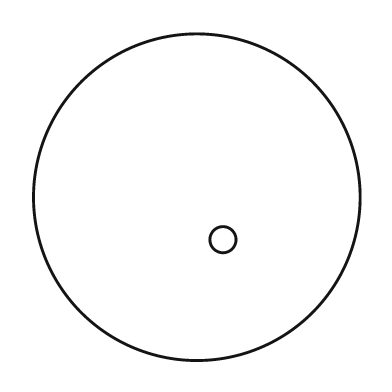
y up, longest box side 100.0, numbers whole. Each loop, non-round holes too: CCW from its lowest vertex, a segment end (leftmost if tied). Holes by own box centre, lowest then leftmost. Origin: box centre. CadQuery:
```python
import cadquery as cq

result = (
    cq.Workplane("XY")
    .moveTo(0.0, 0.0)
    .circle(50.0)
    .moveTo(8.0, -13.0)
    .circle(4.0)
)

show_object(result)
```